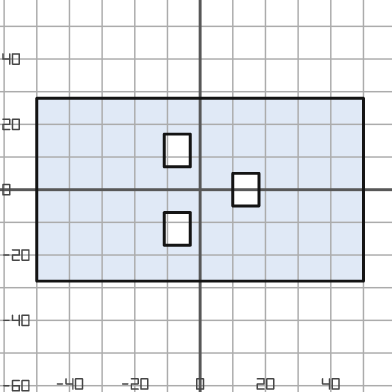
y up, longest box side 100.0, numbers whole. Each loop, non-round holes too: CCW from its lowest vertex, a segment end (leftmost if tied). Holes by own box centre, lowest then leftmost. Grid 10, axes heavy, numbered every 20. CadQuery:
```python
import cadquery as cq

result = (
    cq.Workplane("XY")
    .moveTo(-50.0, -28.0)
    .lineTo(50.0, -28.0)
    .lineTo(50.0, 28.0)
    .lineTo(-50.0, 28.0)
    .close()
    .moveTo(-11.0, -17.0)
    .lineTo(-3.0, -17.0)
    .lineTo(-3.0, -7.0)
    .lineTo(-11.0, -7.0)
    .close()
    .moveTo(10.0, -5.0)
    .lineTo(18.0, -5.0)
    .lineTo(18.0, 5.0)
    .lineTo(10.0, 5.0)
    .close()
    .moveTo(-11.0, 7.0)
    .lineTo(-3.0, 7.0)
    .lineTo(-3.0, 17.0)
    .lineTo(-11.0, 17.0)
    .close()
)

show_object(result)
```